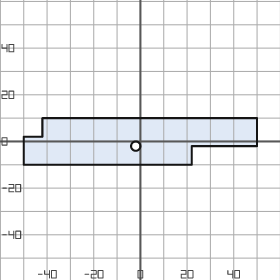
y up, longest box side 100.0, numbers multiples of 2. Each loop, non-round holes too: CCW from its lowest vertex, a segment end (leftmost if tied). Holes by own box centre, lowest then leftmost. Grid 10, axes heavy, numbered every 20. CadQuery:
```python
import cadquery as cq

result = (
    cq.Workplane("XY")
    .moveTo(-50.0, -10.0)
    .lineTo(22.0, -10.0)
    .lineTo(22.0, -2.0)
    .lineTo(50.0, -2.0)
    .lineTo(50.0, 10.0)
    .lineTo(-42.0, 10.0)
    .lineTo(-42.0, 2.0)
    .lineTo(-50.0, 2.0)
    .close()
    .moveTo(-2.0, -2.0)
    .circle(2.0)
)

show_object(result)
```